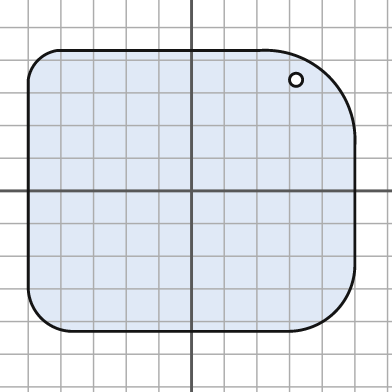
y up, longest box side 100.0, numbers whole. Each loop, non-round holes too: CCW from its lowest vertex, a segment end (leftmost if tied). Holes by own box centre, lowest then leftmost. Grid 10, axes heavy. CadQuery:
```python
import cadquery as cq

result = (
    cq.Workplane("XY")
    .moveTo(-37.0, -43.0)
    .lineTo(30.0, -43.0)
    .threePointArc((44.0, -37.0), (50.0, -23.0))
    .lineTo(50.0, 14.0)
    .threePointArc((42.0, 35.0), (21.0, 43.0))
    .lineTo(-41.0, 43.0)
    .threePointArc((-47.0, 40.0), (-50.0, 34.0))
    .lineTo(-50.0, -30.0)
    .threePointArc((-46.0, -39.0), (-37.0, -43.0))
    .close()
    .moveTo(32.0, 34.0)
    .circle(2.0)
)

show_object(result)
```